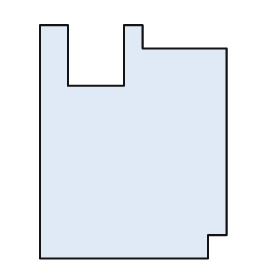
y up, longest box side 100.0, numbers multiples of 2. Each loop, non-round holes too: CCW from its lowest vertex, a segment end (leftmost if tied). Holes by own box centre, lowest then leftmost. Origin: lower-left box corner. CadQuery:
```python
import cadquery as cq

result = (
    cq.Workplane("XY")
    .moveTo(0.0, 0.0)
    .lineTo(72.0, 0.0)
    .lineTo(72.0, 10.0)
    .lineTo(80.0, 10.0)
    .lineTo(80.0, 90.0)
    .lineTo(44.0, 90.0)
    .lineTo(44.0, 100.0)
    .lineTo(36.0, 100.0)
    .lineTo(36.0, 74.0)
    .lineTo(12.0, 74.0)
    .lineTo(12.0, 100.0)
    .lineTo(0.0, 100.0)
    .close()
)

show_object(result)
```